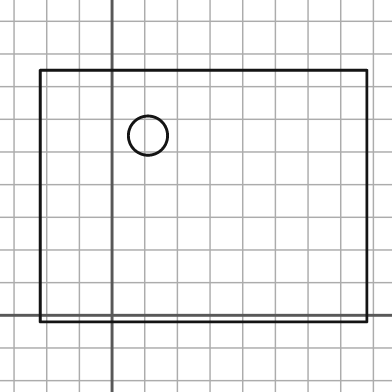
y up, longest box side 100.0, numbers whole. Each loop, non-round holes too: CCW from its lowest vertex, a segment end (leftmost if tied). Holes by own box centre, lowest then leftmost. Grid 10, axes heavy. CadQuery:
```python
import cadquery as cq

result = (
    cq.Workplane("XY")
    .moveTo(-22.0, -2.0)
    .lineTo(78.0, -2.0)
    .lineTo(78.0, 75.0)
    .lineTo(-22.0, 75.0)
    .close()
    .moveTo(11.0, 55.0)
    .circle(6.0)
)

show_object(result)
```